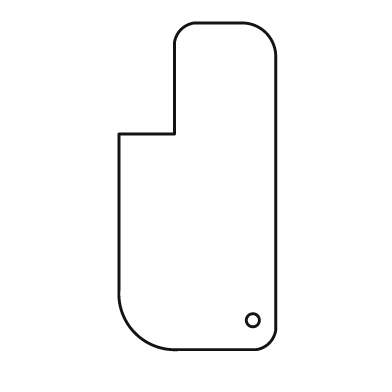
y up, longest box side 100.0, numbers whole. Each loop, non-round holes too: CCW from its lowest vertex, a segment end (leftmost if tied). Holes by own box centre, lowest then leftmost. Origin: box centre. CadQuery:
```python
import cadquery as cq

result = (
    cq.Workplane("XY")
    .moveTo(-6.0, -50.0)
    .lineTo(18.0, -50.0)
    .threePointArc((22.0, -48.0), (24.0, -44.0))
    .lineTo(24.0, 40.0)
    .threePointArc((21.0, 47.0), (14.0, 50.0))
    .lineTo(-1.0, 50.0)
    .threePointArc((-5.0, 48.0), (-7.0, 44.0))
    .lineTo(-7.0, 16.0)
    .lineTo(-24.0, 16.0)
    .lineTo(-24.0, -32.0)
    .threePointArc((-19.0, -45.0), (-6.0, -50.0))
    .close()
    .moveTo(17.0, -41.0)
    .circle(2.0)
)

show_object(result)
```